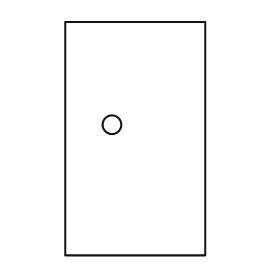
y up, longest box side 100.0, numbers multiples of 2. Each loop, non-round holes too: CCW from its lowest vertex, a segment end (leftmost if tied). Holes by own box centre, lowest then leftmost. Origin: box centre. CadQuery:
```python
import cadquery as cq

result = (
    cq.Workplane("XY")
    .moveTo(-30.0, -50.0)
    .lineTo(30.0, -50.0)
    .lineTo(30.0, 50.0)
    .lineTo(-30.0, 50.0)
    .close()
    .moveTo(-10.0, 6.0)
    .circle(4.0)
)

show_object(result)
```